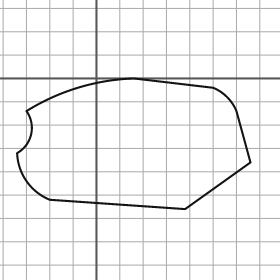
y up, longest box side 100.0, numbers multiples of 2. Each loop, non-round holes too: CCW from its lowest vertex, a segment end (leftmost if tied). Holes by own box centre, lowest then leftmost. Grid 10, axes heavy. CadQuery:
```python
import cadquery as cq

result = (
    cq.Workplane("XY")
    .moveTo(38.0, -56.0)
    .lineTo(66.0, -36.0)
    .lineTo(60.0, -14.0)
    .threePointArc((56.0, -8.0), (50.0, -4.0))
    .lineTo(16.0, 0.0)
    .threePointArc((-8.0, -4.0), (-30.0, -14.0))
    .threePointArc((-28.0, -24.0), (-34.0, -32.0))
    .threePointArc((-30.0, -44.0), (-20.0, -52.0))
    .close()
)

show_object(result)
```